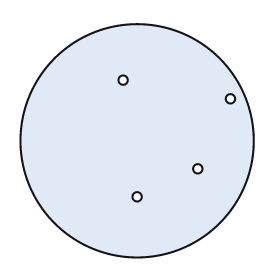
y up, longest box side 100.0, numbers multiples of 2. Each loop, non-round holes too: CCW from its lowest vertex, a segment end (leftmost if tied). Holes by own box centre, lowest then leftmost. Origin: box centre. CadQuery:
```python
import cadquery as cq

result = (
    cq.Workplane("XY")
    .moveTo(0.0, 0.0)
    .circle(50.0)
    .moveTo(0.0, -24.0)
    .circle(2.0)
    .moveTo(26.0, -12.0)
    .circle(2.0)
    .moveTo(40.0, 18.0)
    .circle(2.0)
    .moveTo(-6.0, 26.0)
    .circle(2.0)
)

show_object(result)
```